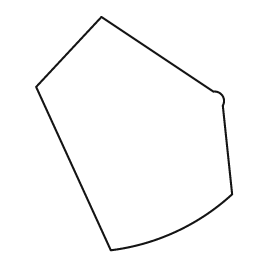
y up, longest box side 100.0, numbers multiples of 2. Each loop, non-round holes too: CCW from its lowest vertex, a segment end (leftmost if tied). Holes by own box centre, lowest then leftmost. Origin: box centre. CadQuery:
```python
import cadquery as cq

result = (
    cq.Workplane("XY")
    .moveTo(-10.0, -50.0)
    .threePointArc((18.0, -42.0), (42.0, -26.0))
    .lineTo(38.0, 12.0)
    .threePointArc((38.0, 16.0), (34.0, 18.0))
    .lineTo(-14.0, 50.0)
    .lineTo(-42.0, 20.0)
    .close()
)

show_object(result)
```